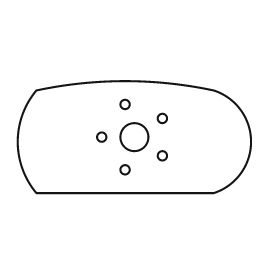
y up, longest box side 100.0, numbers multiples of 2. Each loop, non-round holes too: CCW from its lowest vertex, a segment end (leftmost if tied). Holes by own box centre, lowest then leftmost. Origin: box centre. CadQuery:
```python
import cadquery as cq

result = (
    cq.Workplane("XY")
    .moveTo(-42.0, -24.0)
    .lineTo(34.0, -24.0)
    .threePointArc((50.0, -2.0), (34.0, 20.0))
    .threePointArc((-4.0, 24.0), (-42.0, 20.0))
    .threePointArc((-50.0, -2.0), (-42.0, -24.0))
    .close()
    .moveTo(-4.0, -14.0)
    .circle(2.0)
    .moveTo(12.0, -8.0)
    .circle(2.0)
    .moveTo(-14.0, 0.0)
    .circle(2.0)
    .moveTo(0.0, 0.0)
    .circle(6.0)
    .moveTo(12.0, 8.0)
    .circle(2.0)
    .moveTo(-4.0, 14.0)
    .circle(2.0)
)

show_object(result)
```